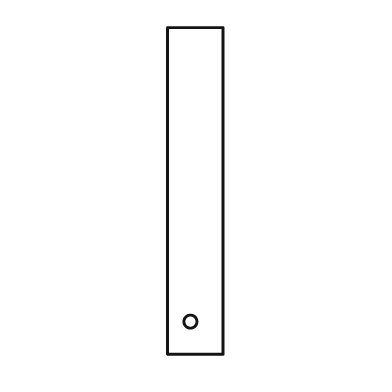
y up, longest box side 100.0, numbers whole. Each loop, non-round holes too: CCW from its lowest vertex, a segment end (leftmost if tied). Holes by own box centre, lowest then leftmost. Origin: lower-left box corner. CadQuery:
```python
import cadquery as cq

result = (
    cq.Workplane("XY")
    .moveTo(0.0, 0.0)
    .lineTo(17.0, 0.0)
    .lineTo(17.0, 100.0)
    .lineTo(0.0, 100.0)
    .close()
    .moveTo(7.0, 10.0)
    .circle(2.0)
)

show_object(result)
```